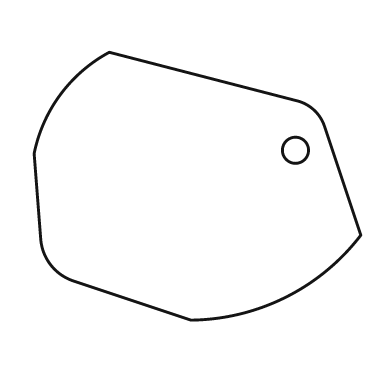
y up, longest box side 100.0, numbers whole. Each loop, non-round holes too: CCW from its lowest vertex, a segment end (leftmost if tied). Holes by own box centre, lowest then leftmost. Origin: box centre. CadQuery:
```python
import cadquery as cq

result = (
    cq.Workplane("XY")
    .moveTo(-2.0, -41.0)
    .threePointArc((27.0, -34.0), (50.0, -15.0))
    .lineTo(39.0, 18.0)
    .threePointArc((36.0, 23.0), (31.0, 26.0))
    .lineTo(-27.0, 41.0)
    .threePointArc((-42.0, 28.0), (-50.0, 10.0))
    .lineTo(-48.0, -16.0)
    .threePointArc((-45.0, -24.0), (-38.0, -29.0))
    .close()
    .moveTo(30.0, 11.0)
    .circle(4.0)
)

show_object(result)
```